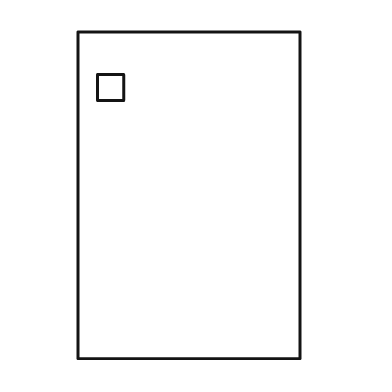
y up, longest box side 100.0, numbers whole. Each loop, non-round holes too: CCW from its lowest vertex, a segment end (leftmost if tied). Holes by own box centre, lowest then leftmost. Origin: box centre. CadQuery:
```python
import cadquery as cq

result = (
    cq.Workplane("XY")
    .moveTo(-34.0, -50.0)
    .lineTo(34.0, -50.0)
    .lineTo(34.0, 50.0)
    .lineTo(-34.0, 50.0)
    .close()
    .moveTo(-28.0, 29.0)
    .lineTo(-20.0, 29.0)
    .lineTo(-20.0, 37.0)
    .lineTo(-28.0, 37.0)
    .close()
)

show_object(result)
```